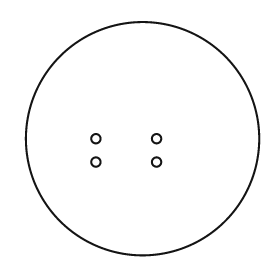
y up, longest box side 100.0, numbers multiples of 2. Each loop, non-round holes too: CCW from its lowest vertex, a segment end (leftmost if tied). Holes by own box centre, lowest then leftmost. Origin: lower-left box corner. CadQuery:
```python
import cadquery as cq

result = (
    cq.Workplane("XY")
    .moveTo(50.0, 50.0)
    .circle(50.0)
    .moveTo(30.0, 40.0)
    .circle(2.0)
    .moveTo(56.0, 40.0)
    .circle(2.0)
    .moveTo(30.0, 50.0)
    .circle(2.0)
    .moveTo(56.0, 50.0)
    .circle(2.0)
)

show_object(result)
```